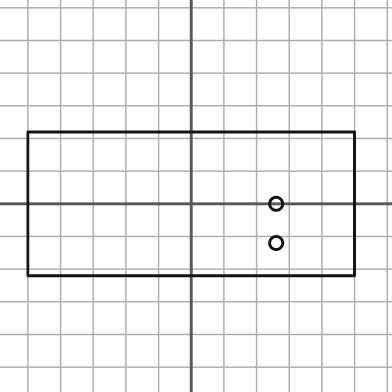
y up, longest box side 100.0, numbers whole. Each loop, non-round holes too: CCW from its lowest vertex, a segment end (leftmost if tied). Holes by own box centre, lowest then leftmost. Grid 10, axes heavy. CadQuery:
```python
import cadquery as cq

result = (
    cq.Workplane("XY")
    .moveTo(-50.0, -22.0)
    .lineTo(50.0, -22.0)
    .lineTo(50.0, 22.0)
    .lineTo(-50.0, 22.0)
    .close()
    .moveTo(26.0, -12.0)
    .circle(2.0)
    .moveTo(26.0, 0.0)
    .circle(2.0)
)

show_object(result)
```